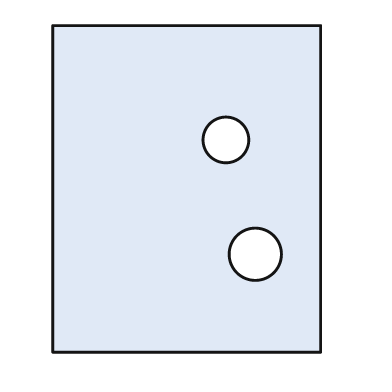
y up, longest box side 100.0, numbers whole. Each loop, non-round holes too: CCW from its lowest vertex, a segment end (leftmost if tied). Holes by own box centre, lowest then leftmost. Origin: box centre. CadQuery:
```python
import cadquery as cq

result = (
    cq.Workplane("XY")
    .moveTo(-41.0, -50.0)
    .lineTo(41.0, -50.0)
    .lineTo(41.0, 50.0)
    .lineTo(-41.0, 50.0)
    .close()
    .moveTo(21.0, -20.0)
    .circle(8.0)
    .moveTo(12.0, 15.0)
    .circle(7.0)
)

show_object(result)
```